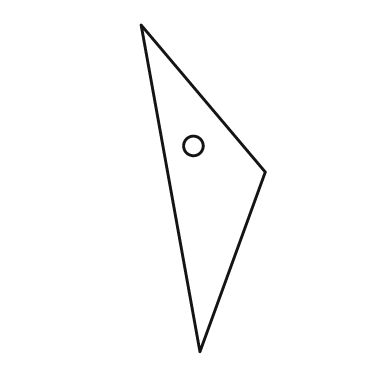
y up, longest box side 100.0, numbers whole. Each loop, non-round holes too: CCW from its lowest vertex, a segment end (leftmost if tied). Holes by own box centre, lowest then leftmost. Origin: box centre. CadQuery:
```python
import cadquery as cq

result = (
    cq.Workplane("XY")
    .moveTo(-1.0, -50.0)
    .lineTo(19.0, 5.0)
    .lineTo(-19.0, 50.0)
    .close()
    .moveTo(-3.0, 13.0)
    .circle(3.0)
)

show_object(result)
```